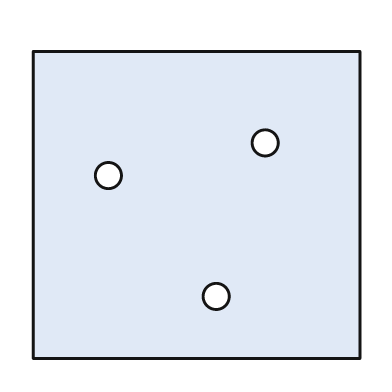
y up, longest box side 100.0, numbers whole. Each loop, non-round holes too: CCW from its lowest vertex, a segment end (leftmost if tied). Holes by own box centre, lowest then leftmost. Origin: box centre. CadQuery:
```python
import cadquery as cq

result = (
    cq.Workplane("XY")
    .moveTo(-50.0, -47.0)
    .lineTo(50.0, -47.0)
    .lineTo(50.0, 47.0)
    .lineTo(-50.0, 47.0)
    .close()
    .moveTo(6.0, -28.0)
    .circle(4.0)
    .moveTo(-27.0, 9.0)
    .circle(4.0)
    .moveTo(21.0, 19.0)
    .circle(4.0)
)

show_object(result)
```